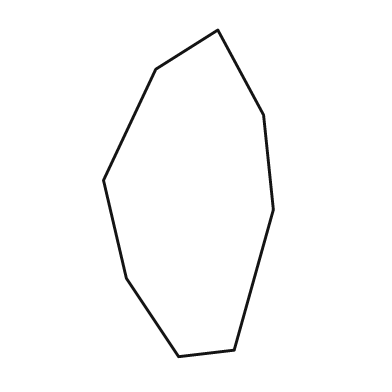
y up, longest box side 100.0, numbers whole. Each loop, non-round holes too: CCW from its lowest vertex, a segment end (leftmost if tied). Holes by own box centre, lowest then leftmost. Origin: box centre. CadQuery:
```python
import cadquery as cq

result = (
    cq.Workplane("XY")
    .moveTo(-3.0, -50.0)
    .lineTo(14.0, -48.0)
    .lineTo(26.0, -5.0)
    .lineTo(23.0, 24.0)
    .lineTo(9.0, 50.0)
    .lineTo(-10.0, 38.0)
    .lineTo(-26.0, 4.0)
    .lineTo(-19.0, -26.0)
    .close()
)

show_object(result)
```